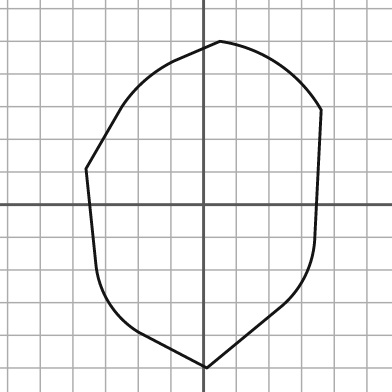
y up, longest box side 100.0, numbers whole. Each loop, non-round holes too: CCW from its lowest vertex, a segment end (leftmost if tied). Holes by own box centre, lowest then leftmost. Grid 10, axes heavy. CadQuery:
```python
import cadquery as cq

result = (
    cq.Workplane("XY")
    .moveTo(1.0, -50.0)
    .lineTo(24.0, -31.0)
    .threePointArc((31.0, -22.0), (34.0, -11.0))
    .lineTo(36.0, 29.0)
    .threePointArc((23.0, 43.0), (5.0, 50.0))
    .lineTo(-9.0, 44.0)
    .threePointArc((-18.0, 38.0), (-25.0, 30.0))
    .lineTo(-36.0, 11.0)
    .lineTo(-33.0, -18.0)
    .threePointArc((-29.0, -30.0), (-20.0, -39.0))
    .close()
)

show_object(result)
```